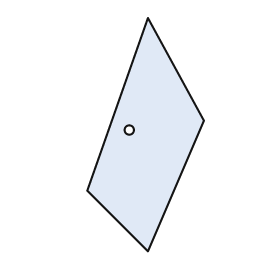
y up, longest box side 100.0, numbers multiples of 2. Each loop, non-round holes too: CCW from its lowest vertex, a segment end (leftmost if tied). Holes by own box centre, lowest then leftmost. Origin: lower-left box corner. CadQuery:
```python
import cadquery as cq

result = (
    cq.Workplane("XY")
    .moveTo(26.0, 0.0)
    .lineTo(50.0, 56.0)
    .lineTo(26.0, 100.0)
    .lineTo(0.0, 26.0)
    .close()
    .moveTo(18.0, 52.0)
    .circle(2.0)
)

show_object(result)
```